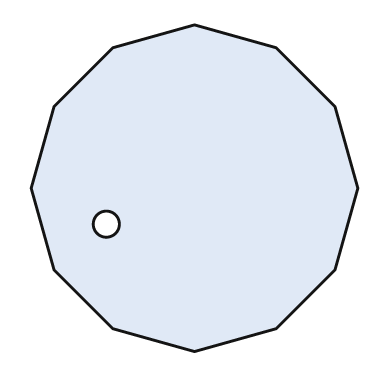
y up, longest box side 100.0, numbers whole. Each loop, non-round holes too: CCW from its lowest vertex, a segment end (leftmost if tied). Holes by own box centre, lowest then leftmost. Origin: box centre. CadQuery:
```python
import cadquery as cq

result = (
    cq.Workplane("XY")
    .moveTo(0.0, -50.0)
    .lineTo(25.0, -43.0)
    .lineTo(43.0, -25.0)
    .lineTo(50.0, 0.0)
    .lineTo(43.0, 25.0)
    .lineTo(25.0, 43.0)
    .lineTo(0.0, 50.0)
    .lineTo(-25.0, 43.0)
    .lineTo(-43.0, 25.0)
    .lineTo(-50.0, 0.0)
    .lineTo(-43.0, -25.0)
    .lineTo(-25.0, -43.0)
    .close()
    .moveTo(-27.0, -11.0)
    .circle(4.0)
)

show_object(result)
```